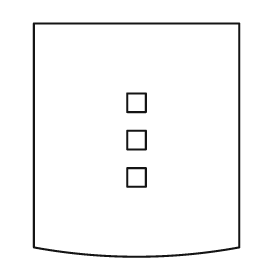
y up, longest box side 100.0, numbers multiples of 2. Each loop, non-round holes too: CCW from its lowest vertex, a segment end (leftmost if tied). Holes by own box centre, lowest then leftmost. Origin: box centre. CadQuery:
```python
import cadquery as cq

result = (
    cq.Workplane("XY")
    .moveTo(-44.0, -46.0)
    .threePointArc((0.0, -50.0), (44.0, -46.0))
    .lineTo(44.0, 50.0)
    .lineTo(-44.0, 50.0)
    .close()
    .moveTo(-4.0, -20.0)
    .lineTo(4.0, -20.0)
    .lineTo(4.0, -12.0)
    .lineTo(-4.0, -12.0)
    .close()
    .moveTo(-4.0, -4.0)
    .lineTo(4.0, -4.0)
    .lineTo(4.0, 4.0)
    .lineTo(-4.0, 4.0)
    .close()
    .moveTo(-4.0, 12.0)
    .lineTo(4.0, 12.0)
    .lineTo(4.0, 20.0)
    .lineTo(-4.0, 20.0)
    .close()
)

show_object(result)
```